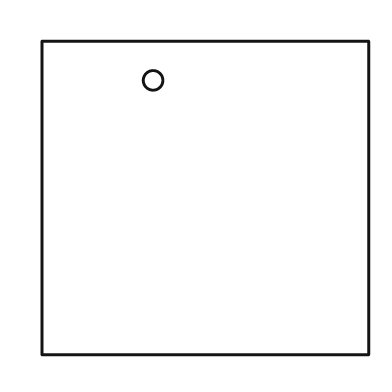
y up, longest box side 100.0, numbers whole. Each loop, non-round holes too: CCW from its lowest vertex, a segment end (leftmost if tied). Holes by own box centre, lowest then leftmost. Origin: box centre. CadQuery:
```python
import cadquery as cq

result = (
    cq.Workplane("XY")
    .moveTo(-50.0, -48.0)
    .lineTo(50.0, -48.0)
    .lineTo(50.0, 48.0)
    .lineTo(-50.0, 48.0)
    .close()
    .moveTo(-16.0, 36.0)
    .circle(3.0)
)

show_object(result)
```